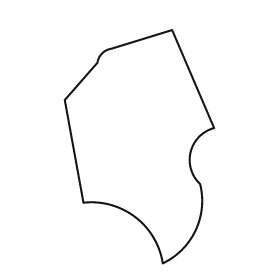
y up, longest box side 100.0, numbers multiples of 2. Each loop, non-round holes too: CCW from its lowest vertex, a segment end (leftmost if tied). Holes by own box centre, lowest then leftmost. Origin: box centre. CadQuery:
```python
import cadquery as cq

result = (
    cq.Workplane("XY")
    .moveTo(10.0, -50.0)
    .threePointArc((24.0, -36.0), (26.0, -16.0))
    .threePointArc((22.0, -2.0), (32.0, 8.0))
    .lineTo(14.0, 50.0)
    .lineTo(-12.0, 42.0)
    .threePointArc((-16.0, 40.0), (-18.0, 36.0))
    .lineTo(-32.0, 20.0)
    .lineTo(-24.0, -24.0)
    .threePointArc((-2.0, -30.0), (10.0, -50.0))
    .close()
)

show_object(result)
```